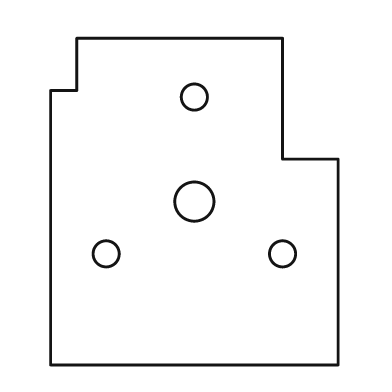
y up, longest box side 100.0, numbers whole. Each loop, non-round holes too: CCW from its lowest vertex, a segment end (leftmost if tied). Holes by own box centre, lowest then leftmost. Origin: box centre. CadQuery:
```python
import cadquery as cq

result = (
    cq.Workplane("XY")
    .moveTo(-44.0, -50.0)
    .lineTo(44.0, -50.0)
    .lineTo(44.0, 13.0)
    .lineTo(27.0, 13.0)
    .lineTo(27.0, 50.0)
    .lineTo(-36.0, 50.0)
    .lineTo(-36.0, 34.0)
    .lineTo(-44.0, 34.0)
    .close()
    .moveTo(-27.0, -16.0)
    .circle(4.0)
    .moveTo(27.0, -16.0)
    .circle(4.0)
    .moveTo(0.0, 0.0)
    .circle(6.0)
    .moveTo(0.0, 32.0)
    .circle(4.0)
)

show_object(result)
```